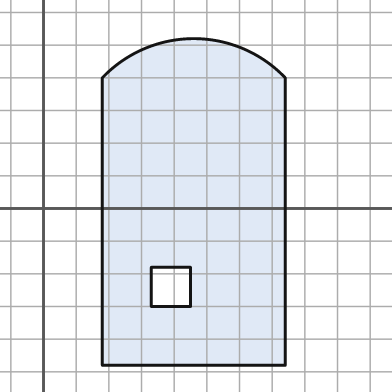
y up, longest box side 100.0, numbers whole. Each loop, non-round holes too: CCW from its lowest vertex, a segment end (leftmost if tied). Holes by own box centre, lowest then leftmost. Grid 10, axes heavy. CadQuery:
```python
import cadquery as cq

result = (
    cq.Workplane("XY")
    .moveTo(18.0, -48.0)
    .lineTo(74.0, -48.0)
    .lineTo(74.0, 40.0)
    .threePointArc((46.0, 52.0), (18.0, 40.0))
    .close()
    .moveTo(33.0, -30.0)
    .lineTo(45.0, -30.0)
    .lineTo(45.0, -18.0)
    .lineTo(33.0, -18.0)
    .close()
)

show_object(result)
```